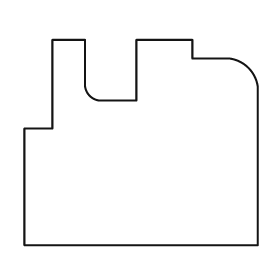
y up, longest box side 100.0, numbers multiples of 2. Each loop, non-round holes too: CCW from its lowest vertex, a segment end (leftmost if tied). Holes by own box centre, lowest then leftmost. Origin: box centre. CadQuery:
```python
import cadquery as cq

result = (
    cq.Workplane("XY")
    .moveTo(-50.0, -44.0)
    .lineTo(50.0, -44.0)
    .lineTo(50.0, 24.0)
    .threePointArc((46.0, 32.0), (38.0, 36.0))
    .lineTo(22.0, 36.0)
    .lineTo(22.0, 44.0)
    .lineTo(-2.0, 44.0)
    .lineTo(-2.0, 18.0)
    .lineTo(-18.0, 18.0)
    .threePointArc((-22.0, 20.0), (-24.0, 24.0))
    .lineTo(-24.0, 44.0)
    .lineTo(-38.0, 44.0)
    .lineTo(-38.0, 6.0)
    .lineTo(-50.0, 6.0)
    .close()
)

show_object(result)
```